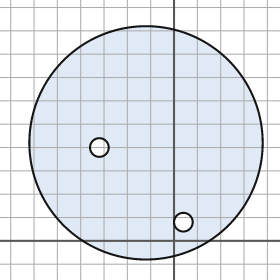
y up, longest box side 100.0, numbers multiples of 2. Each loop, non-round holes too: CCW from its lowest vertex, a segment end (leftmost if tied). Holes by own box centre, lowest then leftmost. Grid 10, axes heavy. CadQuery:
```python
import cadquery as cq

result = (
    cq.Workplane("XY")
    .moveTo(-12.0, 42.0)
    .circle(50.0)
    .moveTo(4.0, 8.0)
    .circle(4.0)
    .moveTo(-32.0, 40.0)
    .circle(4.0)
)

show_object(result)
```